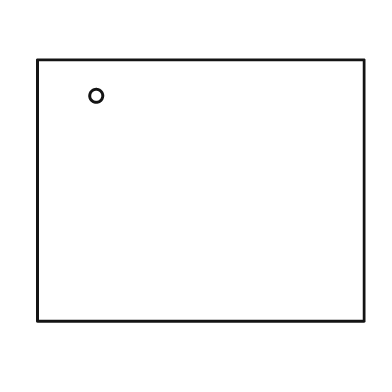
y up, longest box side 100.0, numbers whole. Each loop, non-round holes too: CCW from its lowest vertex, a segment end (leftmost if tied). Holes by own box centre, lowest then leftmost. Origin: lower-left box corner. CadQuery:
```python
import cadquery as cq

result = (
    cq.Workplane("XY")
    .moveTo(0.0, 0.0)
    .lineTo(100.0, 0.0)
    .lineTo(100.0, 80.0)
    .lineTo(0.0, 80.0)
    .close()
    .moveTo(18.0, 69.0)
    .circle(2.0)
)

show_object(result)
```